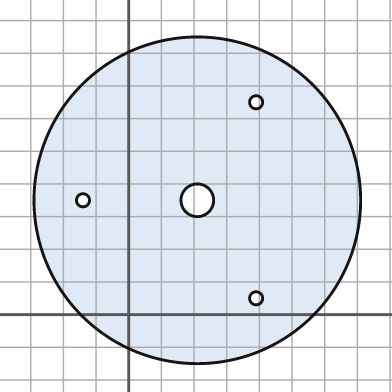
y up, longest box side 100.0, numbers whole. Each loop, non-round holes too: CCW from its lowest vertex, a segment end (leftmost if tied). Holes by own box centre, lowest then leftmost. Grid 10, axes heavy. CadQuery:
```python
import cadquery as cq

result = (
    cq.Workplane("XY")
    .moveTo(21.0, 35.0)
    .circle(50.0)
    .moveTo(39.0, 5.0)
    .circle(2.0)
    .moveTo(-14.0, 35.0)
    .circle(2.0)
    .moveTo(21.0, 35.0)
    .circle(5.0)
    .moveTo(39.0, 65.0)
    .circle(2.0)
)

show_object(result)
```